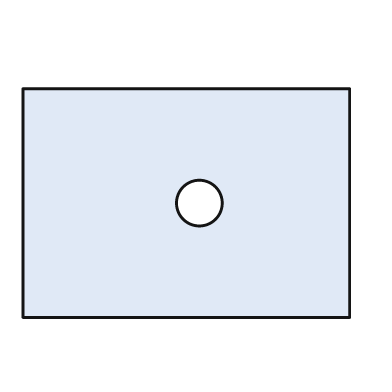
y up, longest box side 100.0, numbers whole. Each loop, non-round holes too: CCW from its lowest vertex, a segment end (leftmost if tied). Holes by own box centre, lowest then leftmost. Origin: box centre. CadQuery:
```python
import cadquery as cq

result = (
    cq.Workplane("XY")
    .moveTo(-50.0, -35.0)
    .lineTo(50.0, -35.0)
    .lineTo(50.0, 35.0)
    .lineTo(-50.0, 35.0)
    .close()
    .moveTo(4.0, 0.0)
    .circle(7.0)
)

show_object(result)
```